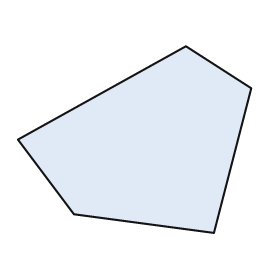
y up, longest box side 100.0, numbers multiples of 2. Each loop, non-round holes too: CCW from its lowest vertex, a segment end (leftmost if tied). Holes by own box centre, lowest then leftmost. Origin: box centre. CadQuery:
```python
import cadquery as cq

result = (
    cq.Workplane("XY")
    .moveTo(34.0, -40.0)
    .lineTo(50.0, 22.0)
    .lineTo(22.0, 40.0)
    .lineTo(-50.0, 0.0)
    .lineTo(-26.0, -32.0)
    .close()
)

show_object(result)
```